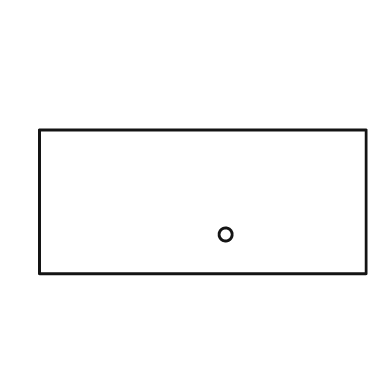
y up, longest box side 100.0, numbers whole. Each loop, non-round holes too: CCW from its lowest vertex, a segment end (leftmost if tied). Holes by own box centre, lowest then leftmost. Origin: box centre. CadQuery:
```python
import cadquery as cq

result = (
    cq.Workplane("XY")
    .moveTo(-50.0, -22.0)
    .lineTo(50.0, -22.0)
    .lineTo(50.0, 22.0)
    .lineTo(-50.0, 22.0)
    .close()
    .moveTo(7.0, -10.0)
    .circle(2.0)
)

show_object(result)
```